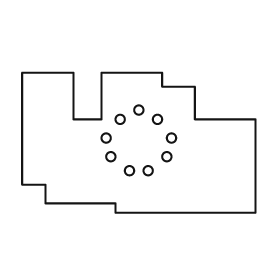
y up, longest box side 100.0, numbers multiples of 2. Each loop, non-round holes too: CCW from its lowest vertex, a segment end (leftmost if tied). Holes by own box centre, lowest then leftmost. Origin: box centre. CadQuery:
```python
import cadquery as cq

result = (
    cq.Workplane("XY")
    .moveTo(-10.0, -30.0)
    .lineTo(50.0, -30.0)
    .lineTo(50.0, 10.0)
    .lineTo(24.0, 10.0)
    .lineTo(24.0, 24.0)
    .lineTo(10.0, 24.0)
    .lineTo(10.0, 30.0)
    .lineTo(-16.0, 30.0)
    .lineTo(-16.0, 10.0)
    .lineTo(-28.0, 10.0)
    .lineTo(-28.0, 30.0)
    .lineTo(-50.0, 30.0)
    .lineTo(-50.0, -18.0)
    .lineTo(-40.0, -18.0)
    .lineTo(-40.0, -26.0)
    .lineTo(-10.0, -26.0)
    .close()
    .moveTo(-4.0, -12.0)
    .circle(2.0)
    .moveTo(4.0, -12.0)
    .circle(2.0)
    .moveTo(-12.0, -6.0)
    .circle(2.0)
    .moveTo(12.0, -6.0)
    .circle(2.0)
    .moveTo(-14.0, 2.0)
    .circle(2.0)
    .moveTo(14.0, 2.0)
    .circle(2.0)
    .moveTo(-8.0, 10.0)
    .circle(2.0)
    .moveTo(8.0, 10.0)
    .circle(2.0)
    .moveTo(0.0, 14.0)
    .circle(2.0)
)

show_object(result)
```